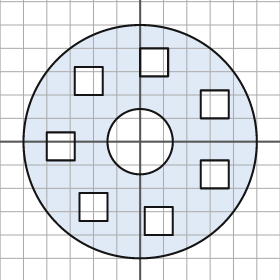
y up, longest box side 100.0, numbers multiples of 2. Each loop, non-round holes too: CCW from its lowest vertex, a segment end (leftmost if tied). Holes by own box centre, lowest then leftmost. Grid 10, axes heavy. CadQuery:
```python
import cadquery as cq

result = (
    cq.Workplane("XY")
    .moveTo(0.0, 0.0)
    .circle(50.0)
    .moveTo(2.0, -40.0)
    .lineTo(14.0, -40.0)
    .lineTo(14.0, -28.0)
    .lineTo(2.0, -28.0)
    .close()
    .moveTo(-26.0, -34.0)
    .lineTo(-14.0, -34.0)
    .lineTo(-14.0, -22.0)
    .lineTo(-26.0, -22.0)
    .close()
    .moveTo(26.0, -20.0)
    .lineTo(38.0, -20.0)
    .lineTo(38.0, -8.0)
    .lineTo(26.0, -8.0)
    .close()
    .moveTo(-40.0, -8.0)
    .lineTo(-28.0, -8.0)
    .lineTo(-28.0, 4.0)
    .lineTo(-40.0, 4.0)
    .close()
    .moveTo(0.0, 0.0)
    .circle(14.0)
    .moveTo(26.0, 10.0)
    .lineTo(38.0, 10.0)
    .lineTo(38.0, 22.0)
    .lineTo(26.0, 22.0)
    .close()
    .moveTo(-28.0, 20.0)
    .lineTo(-16.0, 20.0)
    .lineTo(-16.0, 32.0)
    .lineTo(-28.0, 32.0)
    .close()
    .moveTo(0.0, 28.0)
    .lineTo(12.0, 28.0)
    .lineTo(12.0, 40.0)
    .lineTo(0.0, 40.0)
    .close()
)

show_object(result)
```